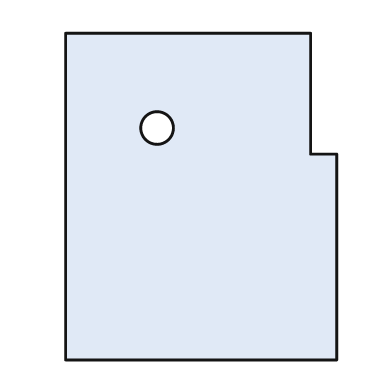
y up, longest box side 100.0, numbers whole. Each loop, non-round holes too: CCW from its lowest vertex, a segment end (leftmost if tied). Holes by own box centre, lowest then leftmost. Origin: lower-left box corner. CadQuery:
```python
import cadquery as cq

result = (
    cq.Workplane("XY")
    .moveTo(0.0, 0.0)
    .lineTo(83.0, 0.0)
    .lineTo(83.0, 63.0)
    .lineTo(75.0, 63.0)
    .lineTo(75.0, 100.0)
    .lineTo(0.0, 100.0)
    .close()
    .moveTo(28.0, 71.0)
    .circle(5.0)
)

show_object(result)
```